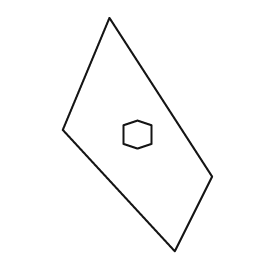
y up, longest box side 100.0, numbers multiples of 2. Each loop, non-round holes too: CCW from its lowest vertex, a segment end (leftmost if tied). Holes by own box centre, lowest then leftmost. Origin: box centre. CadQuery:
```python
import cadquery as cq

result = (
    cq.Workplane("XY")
    .moveTo(16.0, -50.0)
    .lineTo(32.0, -18.0)
    .lineTo(-12.0, 50.0)
    .lineTo(-32.0, 2.0)
    .close()
    .moveTo(0.0, -6.0)
    .lineTo(6.0, -4.0)
    .lineTo(6.0, 4.0)
    .lineTo(0.0, 6.0)
    .lineTo(-6.0, 4.0)
    .lineTo(-6.0, -4.0)
    .close()
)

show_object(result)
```